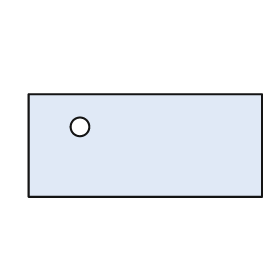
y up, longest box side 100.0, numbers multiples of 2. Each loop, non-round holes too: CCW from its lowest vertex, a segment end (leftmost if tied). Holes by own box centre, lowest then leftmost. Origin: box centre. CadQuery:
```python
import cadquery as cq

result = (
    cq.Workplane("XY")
    .moveTo(-50.0, -22.0)
    .lineTo(50.0, -22.0)
    .lineTo(50.0, 22.0)
    .lineTo(-50.0, 22.0)
    .close()
    .moveTo(-28.0, 8.0)
    .circle(4.0)
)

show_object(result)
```